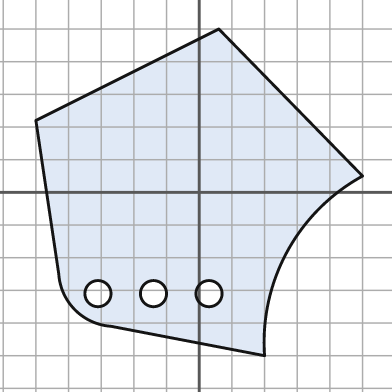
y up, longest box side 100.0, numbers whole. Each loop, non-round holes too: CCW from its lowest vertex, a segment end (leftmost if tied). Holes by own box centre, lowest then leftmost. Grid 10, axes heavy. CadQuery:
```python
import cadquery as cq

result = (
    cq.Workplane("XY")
    .moveTo(20.0, -50.0)
    .threePointArc((27.0, -18.0), (50.0, 5.0))
    .lineTo(6.0, 50.0)
    .lineTo(-50.0, 22.0)
    .lineTo(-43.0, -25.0)
    .threePointArc((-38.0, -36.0), (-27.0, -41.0))
    .close()
    .moveTo(-31.0, -31.0)
    .circle(4.0)
    .moveTo(-14.0, -31.0)
    .circle(4.0)
    .moveTo(3.0, -31.0)
    .circle(4.0)
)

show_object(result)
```